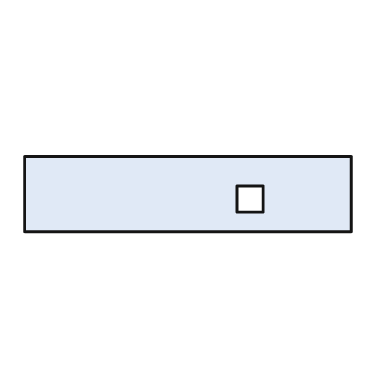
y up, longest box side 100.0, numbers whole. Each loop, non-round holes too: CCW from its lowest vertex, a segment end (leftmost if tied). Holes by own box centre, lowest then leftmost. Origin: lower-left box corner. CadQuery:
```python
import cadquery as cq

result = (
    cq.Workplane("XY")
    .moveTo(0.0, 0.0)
    .lineTo(100.0, 0.0)
    .lineTo(100.0, 23.0)
    .lineTo(0.0, 23.0)
    .close()
    .moveTo(65.0, 6.0)
    .lineTo(73.0, 6.0)
    .lineTo(73.0, 14.0)
    .lineTo(65.0, 14.0)
    .close()
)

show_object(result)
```